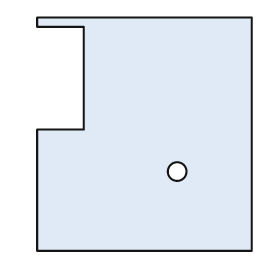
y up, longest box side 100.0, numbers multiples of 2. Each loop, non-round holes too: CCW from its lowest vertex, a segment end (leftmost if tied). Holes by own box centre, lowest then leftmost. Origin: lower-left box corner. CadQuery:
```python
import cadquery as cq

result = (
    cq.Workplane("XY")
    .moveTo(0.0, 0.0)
    .lineTo(92.0, 0.0)
    .lineTo(92.0, 100.0)
    .lineTo(0.0, 100.0)
    .lineTo(0.0, 96.0)
    .lineTo(20.0, 96.0)
    .lineTo(20.0, 52.0)
    .lineTo(0.0, 52.0)
    .close()
    .moveTo(60.0, 34.0)
    .circle(4.0)
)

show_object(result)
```